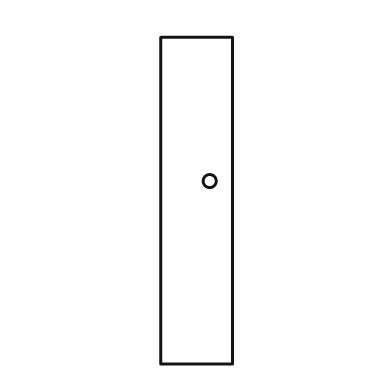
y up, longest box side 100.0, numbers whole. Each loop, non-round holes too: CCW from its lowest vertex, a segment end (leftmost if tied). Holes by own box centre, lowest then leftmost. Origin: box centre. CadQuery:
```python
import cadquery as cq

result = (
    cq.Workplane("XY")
    .moveTo(-11.0, -50.0)
    .lineTo(11.0, -50.0)
    .lineTo(11.0, 50.0)
    .lineTo(-11.0, 50.0)
    .close()
    .moveTo(4.0, 6.0)
    .circle(2.0)
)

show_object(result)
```